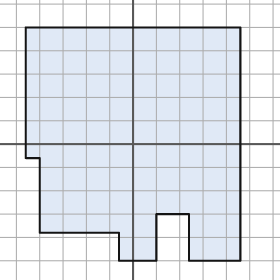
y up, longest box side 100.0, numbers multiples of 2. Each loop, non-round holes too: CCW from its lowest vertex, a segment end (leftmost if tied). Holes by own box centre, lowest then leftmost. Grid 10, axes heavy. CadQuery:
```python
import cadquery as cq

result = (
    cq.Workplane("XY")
    .moveTo(-6.0, -50.0)
    .lineTo(10.0, -50.0)
    .lineTo(10.0, -30.0)
    .lineTo(24.0, -30.0)
    .lineTo(24.0, -50.0)
    .lineTo(46.0, -50.0)
    .lineTo(46.0, 50.0)
    .lineTo(-46.0, 50.0)
    .lineTo(-46.0, -6.0)
    .lineTo(-40.0, -6.0)
    .lineTo(-40.0, -38.0)
    .lineTo(-6.0, -38.0)
    .close()
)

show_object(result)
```